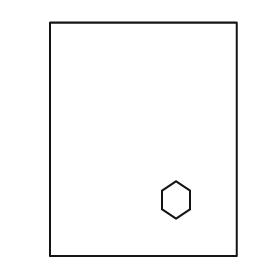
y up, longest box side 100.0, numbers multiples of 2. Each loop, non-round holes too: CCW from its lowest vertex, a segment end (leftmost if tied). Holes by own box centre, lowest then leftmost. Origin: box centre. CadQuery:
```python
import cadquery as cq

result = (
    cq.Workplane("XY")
    .moveTo(-40.0, -50.0)
    .lineTo(40.0, -50.0)
    .lineTo(40.0, 50.0)
    .lineTo(-40.0, 50.0)
    .close()
    .moveTo(14.0, -34.0)
    .lineTo(20.0, -30.0)
    .lineTo(20.0, -22.0)
    .lineTo(14.0, -18.0)
    .lineTo(8.0, -22.0)
    .lineTo(8.0, -30.0)
    .close()
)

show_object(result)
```